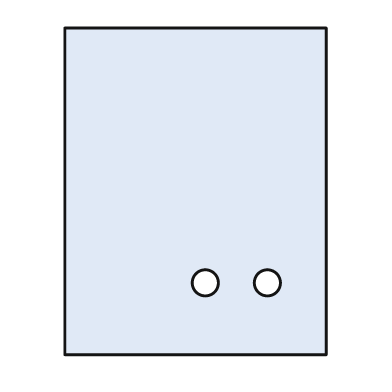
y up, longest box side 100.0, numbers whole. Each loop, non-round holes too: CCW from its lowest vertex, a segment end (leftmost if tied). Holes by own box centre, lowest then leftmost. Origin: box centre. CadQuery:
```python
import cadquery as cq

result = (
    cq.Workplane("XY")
    .moveTo(-40.0, -50.0)
    .lineTo(40.0, -50.0)
    .lineTo(40.0, 50.0)
    .lineTo(-40.0, 50.0)
    .close()
    .moveTo(3.0, -28.0)
    .circle(4.0)
    .moveTo(22.0, -28.0)
    .circle(4.0)
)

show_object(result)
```